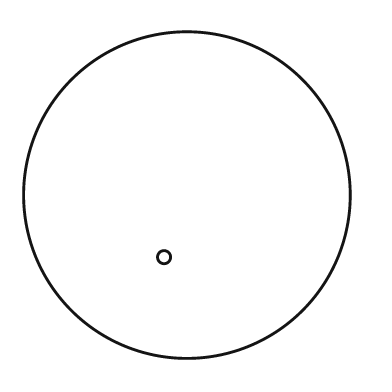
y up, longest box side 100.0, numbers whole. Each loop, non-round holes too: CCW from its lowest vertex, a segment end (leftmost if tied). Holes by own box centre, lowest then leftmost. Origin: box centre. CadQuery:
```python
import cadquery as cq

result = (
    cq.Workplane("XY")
    .moveTo(0.0, 0.0)
    .circle(50.0)
    .moveTo(-7.0, -19.0)
    .circle(2.0)
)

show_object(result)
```